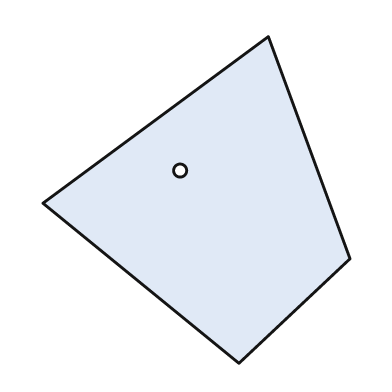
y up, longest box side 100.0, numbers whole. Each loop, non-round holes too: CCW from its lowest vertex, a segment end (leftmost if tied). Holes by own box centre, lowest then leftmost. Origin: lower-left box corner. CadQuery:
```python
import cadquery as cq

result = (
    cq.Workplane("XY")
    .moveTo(60.0, 0.0)
    .lineTo(94.0, 32.0)
    .lineTo(69.0, 100.0)
    .lineTo(0.0, 49.0)
    .close()
    .moveTo(42.0, 59.0)
    .circle(2.0)
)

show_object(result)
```